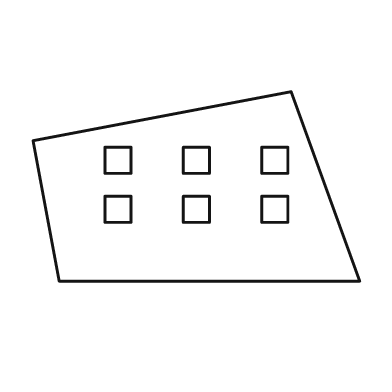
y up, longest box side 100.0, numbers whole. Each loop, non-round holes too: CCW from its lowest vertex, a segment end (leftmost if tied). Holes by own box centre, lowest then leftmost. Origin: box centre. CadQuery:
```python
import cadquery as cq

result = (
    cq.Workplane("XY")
    .moveTo(-42.0, -29.0)
    .lineTo(50.0, -29.0)
    .lineTo(29.0, 29.0)
    .lineTo(-50.0, 14.0)
    .close()
    .moveTo(-28.0, -11.0)
    .lineTo(-20.0, -11.0)
    .lineTo(-20.0, -3.0)
    .lineTo(-28.0, -3.0)
    .close()
    .moveTo(-4.0, -11.0)
    .lineTo(4.0, -11.0)
    .lineTo(4.0, -3.0)
    .lineTo(-4.0, -3.0)
    .close()
    .moveTo(20.0, -11.0)
    .lineTo(28.0, -11.0)
    .lineTo(28.0, -3.0)
    .lineTo(20.0, -3.0)
    .close()
    .moveTo(-28.0, 4.0)
    .lineTo(-20.0, 4.0)
    .lineTo(-20.0, 12.0)
    .lineTo(-28.0, 12.0)
    .close()
    .moveTo(-4.0, 4.0)
    .lineTo(4.0, 4.0)
    .lineTo(4.0, 12.0)
    .lineTo(-4.0, 12.0)
    .close()
    .moveTo(20.0, 4.0)
    .lineTo(28.0, 4.0)
    .lineTo(28.0, 12.0)
    .lineTo(20.0, 12.0)
    .close()
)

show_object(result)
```